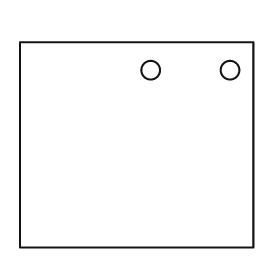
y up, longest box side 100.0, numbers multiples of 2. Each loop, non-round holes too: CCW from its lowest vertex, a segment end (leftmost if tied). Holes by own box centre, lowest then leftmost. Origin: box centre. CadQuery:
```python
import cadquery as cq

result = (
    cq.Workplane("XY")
    .moveTo(-50.0, -44.0)
    .lineTo(50.0, -44.0)
    .lineTo(50.0, 44.0)
    .lineTo(-50.0, 44.0)
    .close()
    .moveTo(6.0, 32.0)
    .circle(4.0)
    .moveTo(40.0, 32.0)
    .circle(4.0)
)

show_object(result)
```